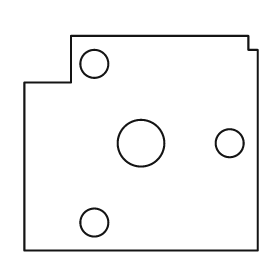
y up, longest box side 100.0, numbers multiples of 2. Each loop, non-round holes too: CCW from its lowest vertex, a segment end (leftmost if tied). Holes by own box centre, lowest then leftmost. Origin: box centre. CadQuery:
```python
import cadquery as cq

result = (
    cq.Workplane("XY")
    .moveTo(-50.0, -46.0)
    .lineTo(50.0, -46.0)
    .lineTo(50.0, 40.0)
    .lineTo(46.0, 40.0)
    .lineTo(46.0, 46.0)
    .lineTo(-30.0, 46.0)
    .lineTo(-30.0, 26.0)
    .lineTo(-50.0, 26.0)
    .close()
    .moveTo(-20.0, -34.0)
    .circle(6.0)
    .moveTo(0.0, 0.0)
    .circle(10.0)
    .moveTo(38.0, 0.0)
    .circle(6.0)
    .moveTo(-20.0, 34.0)
    .circle(6.0)
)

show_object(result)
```